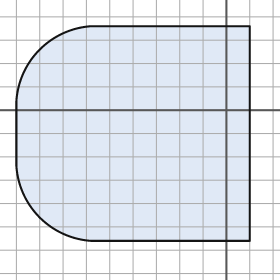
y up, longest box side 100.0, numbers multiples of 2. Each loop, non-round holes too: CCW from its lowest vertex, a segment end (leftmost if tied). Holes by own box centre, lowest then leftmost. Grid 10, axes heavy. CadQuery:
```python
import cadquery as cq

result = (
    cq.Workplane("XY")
    .moveTo(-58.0, -56.0)
    .lineTo(10.0, -56.0)
    .lineTo(10.0, 36.0)
    .lineTo(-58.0, 36.0)
    .threePointArc((-80.0, 26.0), (-90.0, 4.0))
    .lineTo(-90.0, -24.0)
    .threePointArc((-80.0, -46.0), (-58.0, -56.0))
    .close()
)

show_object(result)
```